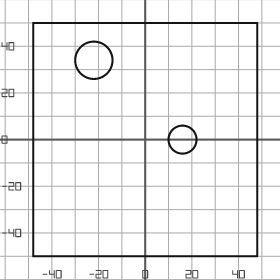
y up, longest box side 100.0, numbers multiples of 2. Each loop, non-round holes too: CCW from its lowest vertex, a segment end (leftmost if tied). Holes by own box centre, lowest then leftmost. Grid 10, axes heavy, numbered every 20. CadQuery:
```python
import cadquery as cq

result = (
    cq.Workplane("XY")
    .moveTo(-48.0, -50.0)
    .lineTo(48.0, -50.0)
    .lineTo(48.0, 50.0)
    .lineTo(-48.0, 50.0)
    .close()
    .moveTo(16.0, 0.0)
    .circle(6.0)
    .moveTo(-22.0, 34.0)
    .circle(8.0)
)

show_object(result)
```